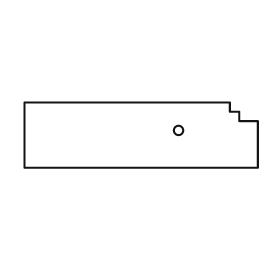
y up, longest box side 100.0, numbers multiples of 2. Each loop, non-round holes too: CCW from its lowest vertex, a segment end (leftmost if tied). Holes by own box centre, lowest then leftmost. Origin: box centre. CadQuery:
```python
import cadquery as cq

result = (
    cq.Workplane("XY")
    .moveTo(-50.0, -14.0)
    .lineTo(50.0, -14.0)
    .lineTo(50.0, 6.0)
    .lineTo(42.0, 6.0)
    .lineTo(42.0, 10.0)
    .lineTo(38.0, 10.0)
    .lineTo(38.0, 14.0)
    .lineTo(-50.0, 14.0)
    .close()
    .moveTo(16.0, 2.0)
    .circle(2.0)
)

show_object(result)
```